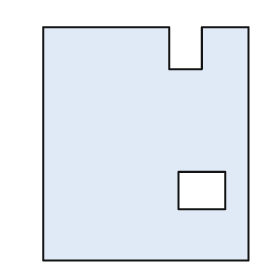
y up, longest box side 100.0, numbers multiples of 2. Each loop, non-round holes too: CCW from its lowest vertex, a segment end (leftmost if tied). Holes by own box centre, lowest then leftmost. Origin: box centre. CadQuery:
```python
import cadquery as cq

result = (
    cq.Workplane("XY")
    .moveTo(-44.0, -50.0)
    .lineTo(44.0, -50.0)
    .lineTo(44.0, 50.0)
    .lineTo(24.0, 50.0)
    .lineTo(24.0, 32.0)
    .lineTo(10.0, 32.0)
    .lineTo(10.0, 50.0)
    .lineTo(-44.0, 50.0)
    .close()
    .moveTo(14.0, -28.0)
    .lineTo(34.0, -28.0)
    .lineTo(34.0, -12.0)
    .lineTo(14.0, -12.0)
    .close()
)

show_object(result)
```